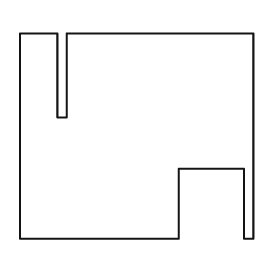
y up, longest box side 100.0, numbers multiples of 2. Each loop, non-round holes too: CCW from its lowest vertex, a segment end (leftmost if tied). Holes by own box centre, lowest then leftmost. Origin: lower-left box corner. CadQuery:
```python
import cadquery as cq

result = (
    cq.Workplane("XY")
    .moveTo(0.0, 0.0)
    .lineTo(68.0, 0.0)
    .lineTo(68.0, 30.0)
    .lineTo(96.0, 30.0)
    .lineTo(96.0, 0.0)
    .lineTo(100.0, 0.0)
    .lineTo(100.0, 88.0)
    .lineTo(20.0, 88.0)
    .lineTo(20.0, 52.0)
    .lineTo(16.0, 52.0)
    .lineTo(16.0, 88.0)
    .lineTo(0.0, 88.0)
    .close()
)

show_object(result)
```